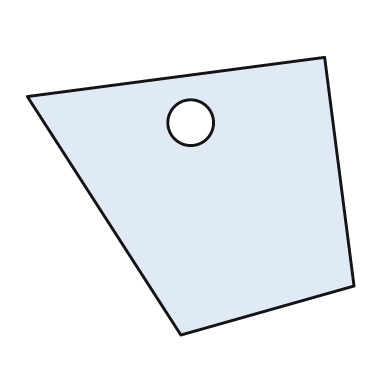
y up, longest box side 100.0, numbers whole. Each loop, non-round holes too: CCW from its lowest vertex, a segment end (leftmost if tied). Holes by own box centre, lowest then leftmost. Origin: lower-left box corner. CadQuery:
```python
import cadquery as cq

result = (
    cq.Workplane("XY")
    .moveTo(47.0, 0.0)
    .lineTo(100.0, 15.0)
    .lineTo(91.0, 85.0)
    .lineTo(0.0, 73.0)
    .close()
    .moveTo(50.0, 65.0)
    .circle(7.0)
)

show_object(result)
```